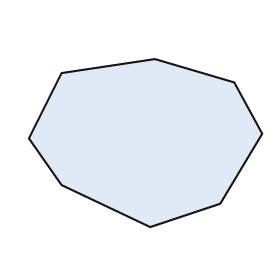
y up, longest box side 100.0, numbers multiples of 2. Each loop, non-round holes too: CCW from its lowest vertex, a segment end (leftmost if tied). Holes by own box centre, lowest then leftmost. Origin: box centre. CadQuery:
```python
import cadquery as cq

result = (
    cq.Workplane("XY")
    .moveTo(2.0, -36.0)
    .lineTo(32.0, -26.0)
    .lineTo(50.0, 4.0)
    .lineTo(38.0, 26.0)
    .lineTo(4.0, 36.0)
    .lineTo(-36.0, 30.0)
    .lineTo(-50.0, 2.0)
    .lineTo(-36.0, -18.0)
    .close()
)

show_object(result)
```